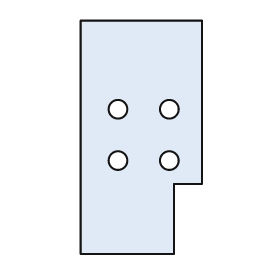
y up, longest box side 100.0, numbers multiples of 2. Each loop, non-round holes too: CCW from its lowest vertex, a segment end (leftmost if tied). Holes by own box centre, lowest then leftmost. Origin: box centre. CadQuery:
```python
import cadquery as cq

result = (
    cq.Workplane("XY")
    .moveTo(-26.0, -50.0)
    .lineTo(14.0, -50.0)
    .lineTo(14.0, -20.0)
    .lineTo(26.0, -20.0)
    .lineTo(26.0, 50.0)
    .lineTo(-26.0, 50.0)
    .close()
    .moveTo(-10.0, -10.0)
    .circle(4.0)
    .moveTo(12.0, -10.0)
    .circle(4.0)
    .moveTo(-10.0, 12.0)
    .circle(4.0)
    .moveTo(12.0, 12.0)
    .circle(4.0)
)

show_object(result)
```